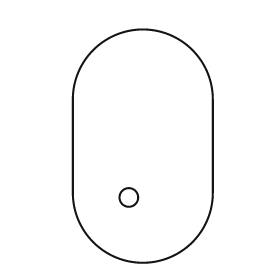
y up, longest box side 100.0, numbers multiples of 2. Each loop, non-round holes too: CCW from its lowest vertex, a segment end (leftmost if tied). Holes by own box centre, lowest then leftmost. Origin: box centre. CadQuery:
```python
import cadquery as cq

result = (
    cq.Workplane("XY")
    .moveTo(-30.0, -20.0)
    .threePointArc((0.0, -50.0), (30.0, -20.0))
    .lineTo(30.0, 20.0)
    .threePointArc((0.0, 50.0), (-30.0, 20.0))
    .close()
    .moveTo(-6.0, -22.0)
    .circle(4.0)
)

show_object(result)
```